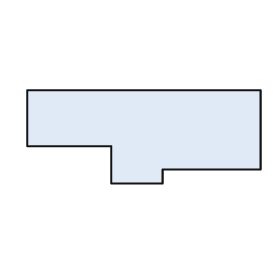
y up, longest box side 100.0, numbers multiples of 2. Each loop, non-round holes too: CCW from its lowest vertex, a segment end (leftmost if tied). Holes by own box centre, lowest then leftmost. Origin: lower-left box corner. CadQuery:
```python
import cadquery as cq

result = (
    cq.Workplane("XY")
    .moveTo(36.0, 0.0)
    .lineTo(58.0, 0.0)
    .lineTo(58.0, 6.0)
    .lineTo(100.0, 6.0)
    .lineTo(100.0, 40.0)
    .lineTo(0.0, 40.0)
    .lineTo(0.0, 16.0)
    .lineTo(36.0, 16.0)
    .close()
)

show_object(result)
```